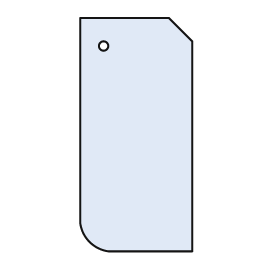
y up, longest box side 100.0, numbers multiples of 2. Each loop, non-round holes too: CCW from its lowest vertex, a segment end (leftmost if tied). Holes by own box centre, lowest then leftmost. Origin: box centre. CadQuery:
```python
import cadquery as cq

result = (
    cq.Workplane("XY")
    .moveTo(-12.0, -50.0)
    .lineTo(24.0, -50.0)
    .lineTo(24.0, 40.0)
    .lineTo(14.0, 50.0)
    .lineTo(-24.0, 50.0)
    .lineTo(-24.0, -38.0)
    .threePointArc((-20.0, -46.0), (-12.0, -50.0))
    .close()
    .moveTo(-14.0, 38.0)
    .circle(2.0)
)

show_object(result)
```